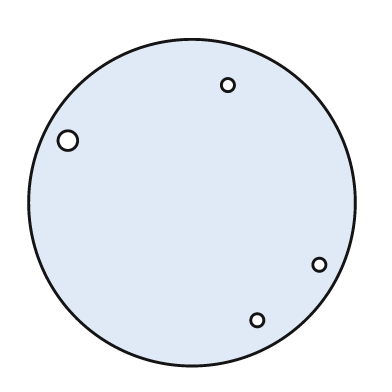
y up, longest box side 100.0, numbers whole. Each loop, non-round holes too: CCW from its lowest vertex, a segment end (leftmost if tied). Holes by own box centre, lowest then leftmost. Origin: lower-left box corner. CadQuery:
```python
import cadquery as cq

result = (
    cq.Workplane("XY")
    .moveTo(50.0, 50.0)
    .circle(50.0)
    .moveTo(70.0, 14.0)
    .circle(2.0)
    .moveTo(89.0, 31.0)
    .circle(2.0)
    .moveTo(12.0, 69.0)
    .circle(3.0)
    .moveTo(61.0, 86.0)
    .circle(2.0)
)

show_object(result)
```